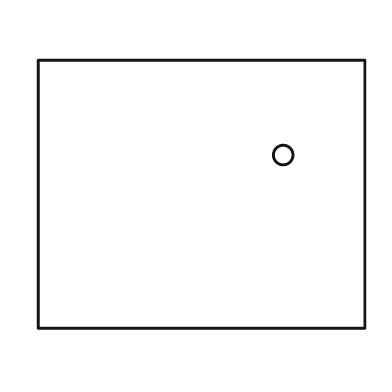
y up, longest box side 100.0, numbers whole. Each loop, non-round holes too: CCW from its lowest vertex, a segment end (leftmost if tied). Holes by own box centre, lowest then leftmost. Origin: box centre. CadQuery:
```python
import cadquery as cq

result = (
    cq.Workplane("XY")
    .moveTo(-50.0, -41.0)
    .lineTo(50.0, -41.0)
    .lineTo(50.0, 41.0)
    .lineTo(-50.0, 41.0)
    .close()
    .moveTo(25.0, 12.0)
    .circle(3.0)
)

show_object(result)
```